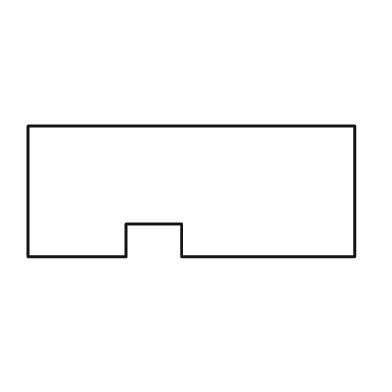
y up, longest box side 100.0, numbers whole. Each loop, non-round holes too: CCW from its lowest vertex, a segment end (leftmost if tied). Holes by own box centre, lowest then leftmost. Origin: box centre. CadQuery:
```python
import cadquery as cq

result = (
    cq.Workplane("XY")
    .moveTo(-50.0, -20.0)
    .lineTo(-20.0, -20.0)
    .lineTo(-20.0, -10.0)
    .lineTo(-3.0, -10.0)
    .lineTo(-3.0, -20.0)
    .lineTo(50.0, -20.0)
    .lineTo(50.0, 20.0)
    .lineTo(-50.0, 20.0)
    .close()
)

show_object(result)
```